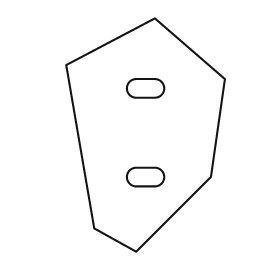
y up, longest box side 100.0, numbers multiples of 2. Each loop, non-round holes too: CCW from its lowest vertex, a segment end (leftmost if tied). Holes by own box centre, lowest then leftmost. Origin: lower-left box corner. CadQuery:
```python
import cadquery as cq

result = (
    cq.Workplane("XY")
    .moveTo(30.0, 0.0)
    .lineTo(62.0, 32.0)
    .lineTo(68.0, 74.0)
    .lineTo(38.0, 100.0)
    .lineTo(0.0, 80.0)
    .lineTo(12.0, 10.0)
    .close()
    .moveTo(30.0, 28.0)
    .lineTo(38.0, 28.0)
    .threePointArc((42.0, 32.0), (38.0, 36.0))
    .lineTo(30.0, 36.0)
    .threePointArc((26.0, 32.0), (30.0, 28.0))
    .close()
    .moveTo(30.0, 66.0)
    .lineTo(38.0, 66.0)
    .threePointArc((42.0, 70.0), (38.0, 74.0))
    .lineTo(30.0, 74.0)
    .threePointArc((26.0, 70.0), (30.0, 66.0))
    .close()
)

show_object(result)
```